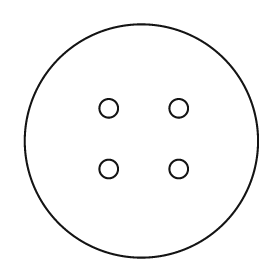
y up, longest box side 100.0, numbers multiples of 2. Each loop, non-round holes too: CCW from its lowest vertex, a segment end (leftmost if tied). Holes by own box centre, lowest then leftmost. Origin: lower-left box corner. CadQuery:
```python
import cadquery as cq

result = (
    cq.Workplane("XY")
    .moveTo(50.0, 50.0)
    .circle(50.0)
    .moveTo(36.0, 38.0)
    .circle(4.0)
    .moveTo(66.0, 38.0)
    .circle(4.0)
    .moveTo(36.0, 64.0)
    .circle(4.0)
    .moveTo(66.0, 64.0)
    .circle(4.0)
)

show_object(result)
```